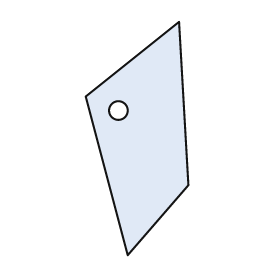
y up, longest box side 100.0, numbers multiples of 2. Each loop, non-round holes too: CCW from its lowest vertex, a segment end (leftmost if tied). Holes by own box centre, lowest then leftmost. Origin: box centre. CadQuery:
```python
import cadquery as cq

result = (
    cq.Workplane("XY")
    .moveTo(-4.0, -50.0)
    .lineTo(22.0, -20.0)
    .lineTo(18.0, 50.0)
    .lineTo(-22.0, 18.0)
    .close()
    .moveTo(-8.0, 12.0)
    .circle(4.0)
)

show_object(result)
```